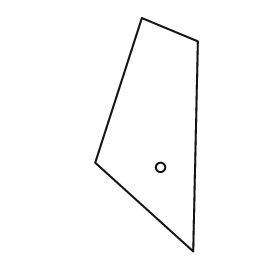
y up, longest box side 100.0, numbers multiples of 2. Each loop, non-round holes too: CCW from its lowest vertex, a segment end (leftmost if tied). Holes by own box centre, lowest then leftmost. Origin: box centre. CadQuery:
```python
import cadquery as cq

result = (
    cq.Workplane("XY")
    .moveTo(20.0, -50.0)
    .lineTo(22.0, 40.0)
    .lineTo(-2.0, 50.0)
    .lineTo(-22.0, -12.0)
    .close()
    .moveTo(6.0, -14.0)
    .circle(2.0)
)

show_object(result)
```